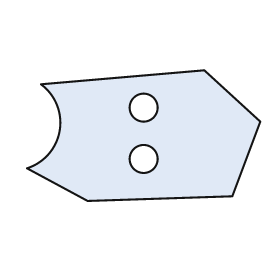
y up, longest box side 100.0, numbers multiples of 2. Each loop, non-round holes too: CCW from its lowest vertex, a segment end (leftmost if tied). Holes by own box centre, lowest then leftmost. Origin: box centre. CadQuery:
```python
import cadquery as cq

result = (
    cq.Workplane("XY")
    .moveTo(-24.0, -28.0)
    .lineTo(38.0, -26.0)
    .lineTo(50.0, 6.0)
    .lineTo(26.0, 28.0)
    .lineTo(-44.0, 22.0)
    .threePointArc((-36.0, 2.0), (-50.0, -14.0))
    .close()
    .moveTo(0.0, -10.0)
    .circle(6.0)
    .moveTo(0.0, 12.0)
    .circle(6.0)
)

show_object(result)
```